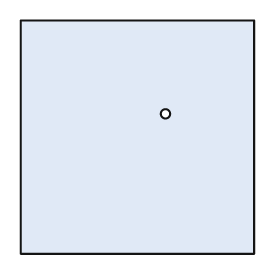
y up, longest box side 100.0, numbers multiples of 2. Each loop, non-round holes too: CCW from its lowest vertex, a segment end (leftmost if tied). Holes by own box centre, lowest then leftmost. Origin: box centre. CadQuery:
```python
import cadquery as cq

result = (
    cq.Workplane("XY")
    .moveTo(-50.0, -50.0)
    .lineTo(50.0, -50.0)
    .lineTo(50.0, 50.0)
    .lineTo(-50.0, 50.0)
    .close()
    .moveTo(12.0, 10.0)
    .circle(2.0)
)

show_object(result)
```